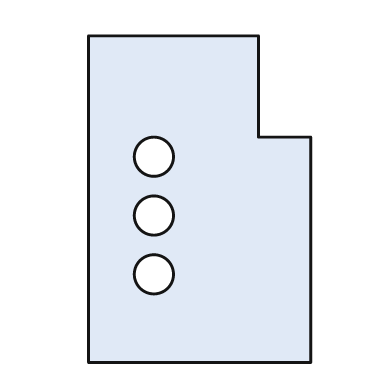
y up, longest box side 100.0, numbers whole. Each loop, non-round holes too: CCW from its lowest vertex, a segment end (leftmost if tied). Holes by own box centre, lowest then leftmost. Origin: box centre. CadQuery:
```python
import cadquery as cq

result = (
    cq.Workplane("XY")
    .moveTo(-34.0, -50.0)
    .lineTo(34.0, -50.0)
    .lineTo(34.0, 19.0)
    .lineTo(18.0, 19.0)
    .lineTo(18.0, 50.0)
    .lineTo(-34.0, 50.0)
    .close()
    .moveTo(-14.0, -23.0)
    .circle(6.0)
    .moveTo(-14.0, -5.0)
    .circle(6.0)
    .moveTo(-14.0, 13.0)
    .circle(6.0)
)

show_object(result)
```